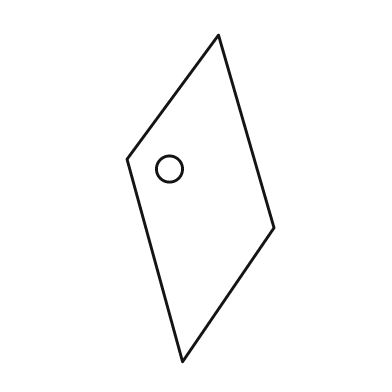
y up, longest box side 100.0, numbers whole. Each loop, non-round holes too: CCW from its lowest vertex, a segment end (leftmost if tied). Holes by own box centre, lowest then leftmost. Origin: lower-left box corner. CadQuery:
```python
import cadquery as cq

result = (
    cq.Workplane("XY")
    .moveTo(17.0, 0.0)
    .lineTo(45.0, 41.0)
    .lineTo(28.0, 100.0)
    .lineTo(0.0, 62.0)
    .close()
    .moveTo(13.0, 59.0)
    .circle(4.0)
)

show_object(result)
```